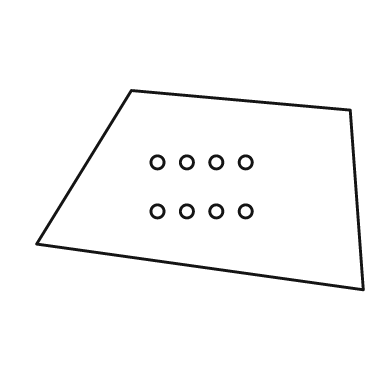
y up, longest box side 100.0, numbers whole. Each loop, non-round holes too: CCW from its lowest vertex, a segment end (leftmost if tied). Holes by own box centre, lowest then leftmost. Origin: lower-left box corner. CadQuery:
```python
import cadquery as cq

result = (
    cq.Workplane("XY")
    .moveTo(100.0, 0.0)
    .lineTo(96.0, 55.0)
    .lineTo(29.0, 61.0)
    .lineTo(0.0, 14.0)
    .close()
    .moveTo(37.0, 24.0)
    .circle(2.0)
    .moveTo(46.0, 24.0)
    .circle(2.0)
    .moveTo(55.0, 24.0)
    .circle(2.0)
    .moveTo(64.0, 24.0)
    .circle(2.0)
    .moveTo(37.0, 39.0)
    .circle(2.0)
    .moveTo(46.0, 39.0)
    .circle(2.0)
    .moveTo(55.0, 39.0)
    .circle(2.0)
    .moveTo(64.0, 39.0)
    .circle(2.0)
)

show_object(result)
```